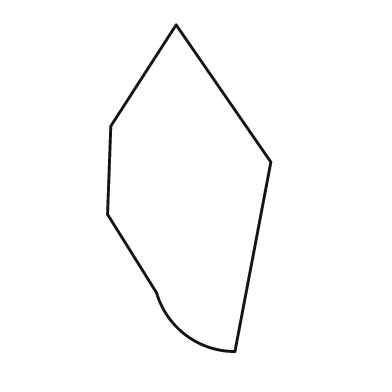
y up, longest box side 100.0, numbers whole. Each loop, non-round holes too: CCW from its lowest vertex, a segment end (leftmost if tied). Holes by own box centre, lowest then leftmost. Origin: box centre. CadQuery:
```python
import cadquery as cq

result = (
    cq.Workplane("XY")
    .moveTo(14.0, -50.0)
    .lineTo(25.0, 8.0)
    .lineTo(-4.0, 50.0)
    .lineTo(-24.0, 19.0)
    .lineTo(-25.0, -8.0)
    .lineTo(-10.0, -32.0)
    .threePointArc((-1.0, -45.0), (14.0, -50.0))
    .close()
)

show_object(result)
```